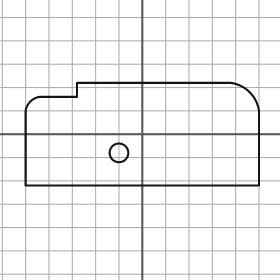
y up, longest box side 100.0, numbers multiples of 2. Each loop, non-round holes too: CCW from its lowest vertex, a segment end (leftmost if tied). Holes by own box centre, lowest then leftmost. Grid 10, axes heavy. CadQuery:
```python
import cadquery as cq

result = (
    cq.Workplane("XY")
    .moveTo(-50.0, -22.0)
    .lineTo(50.0, -22.0)
    .lineTo(50.0, 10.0)
    .threePointArc((46.0, 18.0), (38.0, 22.0))
    .lineTo(-28.0, 22.0)
    .lineTo(-28.0, 16.0)
    .lineTo(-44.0, 16.0)
    .threePointArc((-48.0, 14.0), (-50.0, 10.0))
    .close()
    .moveTo(-10.0, -8.0)
    .circle(4.0)
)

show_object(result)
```